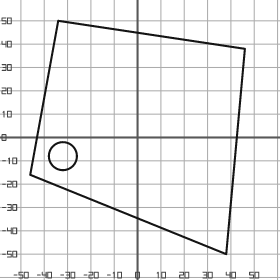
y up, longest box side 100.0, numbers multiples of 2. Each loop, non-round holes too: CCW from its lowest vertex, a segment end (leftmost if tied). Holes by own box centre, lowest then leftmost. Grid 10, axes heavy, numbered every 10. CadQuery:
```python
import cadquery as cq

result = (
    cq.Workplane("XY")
    .moveTo(38.0, -50.0)
    .lineTo(46.0, 38.0)
    .lineTo(-34.0, 50.0)
    .lineTo(-46.0, -16.0)
    .close()
    .moveTo(-32.0, -8.0)
    .circle(6.0)
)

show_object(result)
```